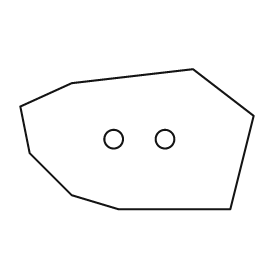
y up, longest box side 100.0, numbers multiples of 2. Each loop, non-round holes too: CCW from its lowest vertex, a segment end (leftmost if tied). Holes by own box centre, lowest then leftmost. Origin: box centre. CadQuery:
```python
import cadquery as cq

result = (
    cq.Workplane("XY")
    .moveTo(-8.0, -30.0)
    .lineTo(40.0, -30.0)
    .lineTo(50.0, 10.0)
    .lineTo(24.0, 30.0)
    .lineTo(-28.0, 24.0)
    .lineTo(-50.0, 14.0)
    .lineTo(-46.0, -6.0)
    .lineTo(-28.0, -24.0)
    .close()
    .moveTo(-10.0, 0.0)
    .circle(4.0)
    .moveTo(12.0, 0.0)
    .circle(4.0)
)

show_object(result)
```